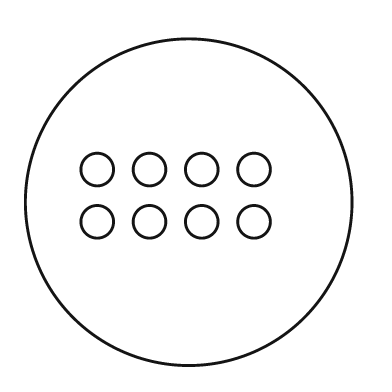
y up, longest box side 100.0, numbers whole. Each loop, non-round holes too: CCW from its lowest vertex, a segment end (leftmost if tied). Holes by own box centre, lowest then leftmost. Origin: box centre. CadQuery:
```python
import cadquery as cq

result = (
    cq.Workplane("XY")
    .moveTo(0.0, 0.0)
    .circle(50.0)
    .moveTo(-28.0, -6.0)
    .circle(5.0)
    .moveTo(-12.0, -6.0)
    .circle(5.0)
    .moveTo(4.0, -6.0)
    .circle(5.0)
    .moveTo(20.0, -6.0)
    .circle(5.0)
    .moveTo(-28.0, 10.0)
    .circle(5.0)
    .moveTo(-12.0, 10.0)
    .circle(5.0)
    .moveTo(4.0, 10.0)
    .circle(5.0)
    .moveTo(20.0, 10.0)
    .circle(5.0)
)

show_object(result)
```